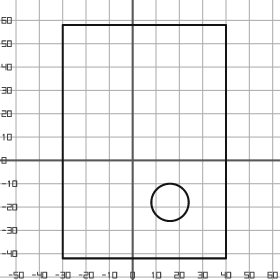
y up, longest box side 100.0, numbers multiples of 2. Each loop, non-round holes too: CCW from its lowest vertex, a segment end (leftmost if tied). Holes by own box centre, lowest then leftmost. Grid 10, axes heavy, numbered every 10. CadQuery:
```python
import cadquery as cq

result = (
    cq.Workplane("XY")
    .moveTo(-30.0, -42.0)
    .lineTo(40.0, -42.0)
    .lineTo(40.0, 58.0)
    .lineTo(-30.0, 58.0)
    .close()
    .moveTo(16.0, -18.0)
    .circle(8.0)
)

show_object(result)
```